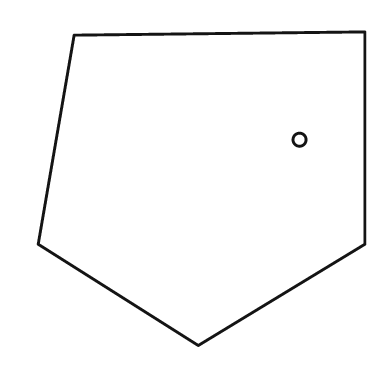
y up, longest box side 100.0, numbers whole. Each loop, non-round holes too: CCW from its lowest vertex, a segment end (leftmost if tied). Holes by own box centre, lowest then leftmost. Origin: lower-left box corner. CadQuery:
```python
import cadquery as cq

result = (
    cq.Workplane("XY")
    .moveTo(49.0, 0.0)
    .lineTo(100.0, 31.0)
    .lineTo(100.0, 96.0)
    .lineTo(11.0, 95.0)
    .lineTo(0.0, 31.0)
    .close()
    .moveTo(80.0, 63.0)
    .circle(2.0)
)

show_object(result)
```